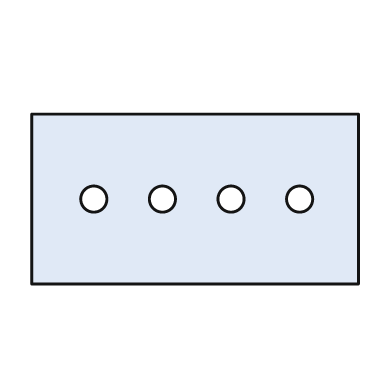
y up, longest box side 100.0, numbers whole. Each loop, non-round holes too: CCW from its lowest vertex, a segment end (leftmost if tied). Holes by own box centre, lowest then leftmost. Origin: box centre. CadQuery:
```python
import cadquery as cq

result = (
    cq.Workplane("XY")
    .moveTo(-50.0, -26.0)
    .lineTo(50.0, -26.0)
    .lineTo(50.0, 26.0)
    .lineTo(-50.0, 26.0)
    .close()
    .moveTo(-31.0, 0.0)
    .circle(4.0)
    .moveTo(-10.0, 0.0)
    .circle(4.0)
    .moveTo(11.0, 0.0)
    .circle(4.0)
    .moveTo(32.0, 0.0)
    .circle(4.0)
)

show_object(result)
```